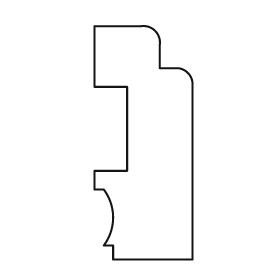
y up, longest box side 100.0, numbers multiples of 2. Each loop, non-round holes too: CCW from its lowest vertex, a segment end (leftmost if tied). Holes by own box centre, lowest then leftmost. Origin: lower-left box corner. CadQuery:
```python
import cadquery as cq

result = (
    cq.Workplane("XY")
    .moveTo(8.0, 0.0)
    .lineTo(42.0, 0.0)
    .lineTo(42.0, 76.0)
    .threePointArc((40.0, 80.0), (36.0, 82.0))
    .lineTo(28.0, 82.0)
    .lineTo(28.0, 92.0)
    .threePointArc((26.0, 98.0), (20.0, 100.0))
    .lineTo(0.0, 100.0)
    .lineTo(0.0, 74.0)
    .lineTo(14.0, 74.0)
    .lineTo(14.0, 38.0)
    .lineTo(0.0, 38.0)
    .lineTo(0.0, 30.0)
    .lineTo(4.0, 30.0)
    .threePointArc((8.0, 18.0), (4.0, 6.0))
    .lineTo(8.0, 6.0)
    .close()
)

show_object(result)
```